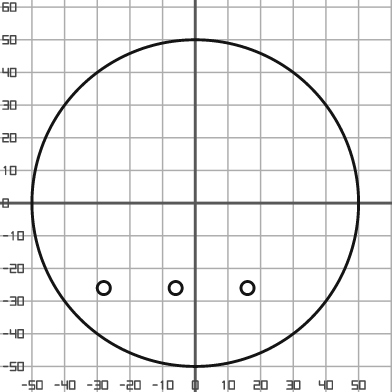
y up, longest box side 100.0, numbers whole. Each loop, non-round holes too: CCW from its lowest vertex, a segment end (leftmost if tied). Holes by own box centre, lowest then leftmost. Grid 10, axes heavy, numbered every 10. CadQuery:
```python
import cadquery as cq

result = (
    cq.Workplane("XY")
    .moveTo(0.0, 0.0)
    .circle(50.0)
    .moveTo(-28.0, -26.0)
    .circle(2.0)
    .moveTo(-6.0, -26.0)
    .circle(2.0)
    .moveTo(16.0, -26.0)
    .circle(2.0)
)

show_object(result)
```